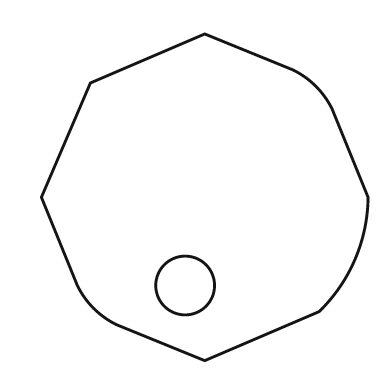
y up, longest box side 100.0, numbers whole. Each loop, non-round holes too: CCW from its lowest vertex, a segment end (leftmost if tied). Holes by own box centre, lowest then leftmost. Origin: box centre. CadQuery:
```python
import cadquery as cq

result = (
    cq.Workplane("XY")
    .moveTo(0.0, -50.0)
    .lineTo(35.0, -35.0)
    .threePointArc((46.0, -19.0), (50.0, 0.0))
    .lineTo(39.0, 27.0)
    .threePointArc((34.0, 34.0), (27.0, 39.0))
    .lineTo(0.0, 50.0)
    .lineTo(-35.0, 35.0)
    .lineTo(-50.0, 0.0)
    .lineTo(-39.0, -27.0)
    .threePointArc((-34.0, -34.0), (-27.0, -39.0))
    .close()
    .moveTo(-6.0, -27.0)
    .circle(9.0)
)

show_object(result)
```